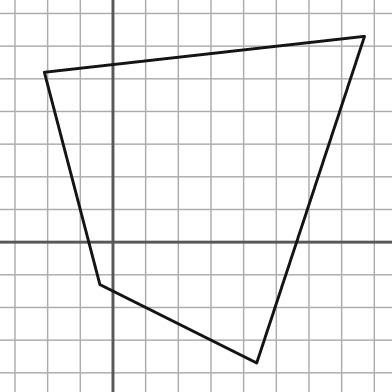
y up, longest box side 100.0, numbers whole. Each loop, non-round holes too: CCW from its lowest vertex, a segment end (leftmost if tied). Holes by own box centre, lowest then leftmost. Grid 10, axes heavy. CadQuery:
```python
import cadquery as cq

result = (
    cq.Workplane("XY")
    .moveTo(44.0, -37.0)
    .lineTo(77.0, 63.0)
    .lineTo(-21.0, 52.0)
    .lineTo(-4.0, -13.0)
    .close()
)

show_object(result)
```